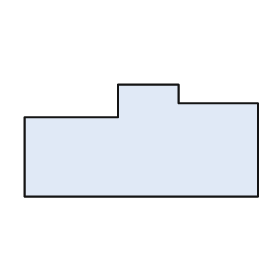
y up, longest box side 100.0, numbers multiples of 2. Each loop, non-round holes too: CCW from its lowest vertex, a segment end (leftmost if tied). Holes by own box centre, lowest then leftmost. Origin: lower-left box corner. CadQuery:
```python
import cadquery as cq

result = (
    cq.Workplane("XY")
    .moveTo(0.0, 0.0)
    .lineTo(100.0, 0.0)
    .lineTo(100.0, 40.0)
    .lineTo(66.0, 40.0)
    .lineTo(66.0, 48.0)
    .lineTo(40.0, 48.0)
    .lineTo(40.0, 34.0)
    .lineTo(0.0, 34.0)
    .close()
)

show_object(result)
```